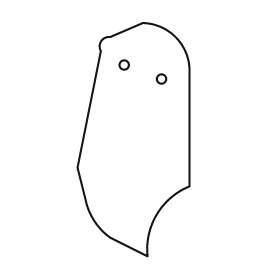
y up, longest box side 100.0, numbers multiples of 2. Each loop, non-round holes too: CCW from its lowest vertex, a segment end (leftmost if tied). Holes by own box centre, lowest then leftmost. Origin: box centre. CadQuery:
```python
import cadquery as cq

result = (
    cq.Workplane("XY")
    .moveTo(6.0, -50.0)
    .threePointArc((10.0, -32.0), (24.0, -20.0))
    .lineTo(24.0, 30.0)
    .threePointArc((18.0, 44.0), (4.0, 50.0))
    .lineTo(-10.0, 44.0)
    .threePointArc((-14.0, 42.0), (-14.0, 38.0))
    .lineTo(-24.0, -12.0)
    .lineTo(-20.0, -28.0)
    .threePointArc((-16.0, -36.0), (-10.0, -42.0))
    .close()
    .moveTo(12.0, 26.0)
    .circle(2.0)
    .moveTo(-4.0, 32.0)
    .circle(2.0)
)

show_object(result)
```